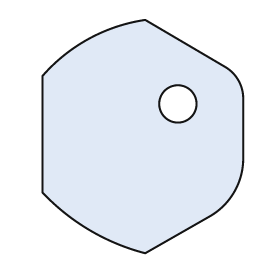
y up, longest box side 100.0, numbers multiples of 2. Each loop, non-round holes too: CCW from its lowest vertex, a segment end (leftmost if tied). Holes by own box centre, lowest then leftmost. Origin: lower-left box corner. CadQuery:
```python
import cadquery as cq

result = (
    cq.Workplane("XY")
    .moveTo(44.0, 0.0)
    .lineTo(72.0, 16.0)
    .threePointArc((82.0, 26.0), (86.0, 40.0))
    .lineTo(86.0, 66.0)
    .threePointArc((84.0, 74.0), (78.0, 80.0))
    .lineTo(44.0, 100.0)
    .threePointArc((20.0, 92.0), (0.0, 76.0))
    .lineTo(0.0, 26.0)
    .threePointArc((20.0, 10.0), (44.0, 0.0))
    .close()
    .moveTo(58.0, 64.0)
    .circle(8.0)
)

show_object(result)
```